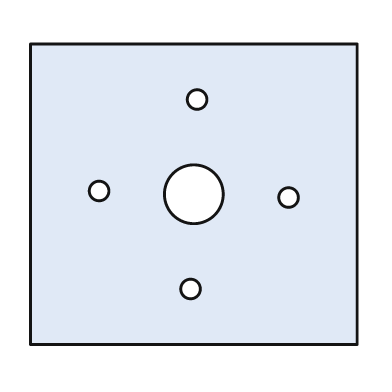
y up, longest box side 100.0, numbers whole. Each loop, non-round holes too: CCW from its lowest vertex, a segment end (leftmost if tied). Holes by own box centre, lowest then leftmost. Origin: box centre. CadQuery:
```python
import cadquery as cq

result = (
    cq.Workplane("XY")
    .moveTo(-50.0, -46.0)
    .lineTo(50.0, -46.0)
    .lineTo(50.0, 46.0)
    .lineTo(-50.0, 46.0)
    .close()
    .moveTo(-1.0, -29.0)
    .circle(3.0)
    .moveTo(29.0, -1.0)
    .circle(3.0)
    .moveTo(0.0, 0.0)
    .circle(9.0)
    .moveTo(-29.0, 1.0)
    .circle(3.0)
    .moveTo(1.0, 29.0)
    .circle(3.0)
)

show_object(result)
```